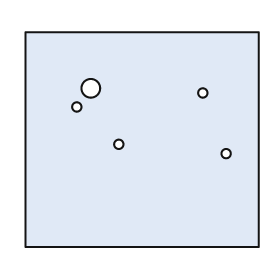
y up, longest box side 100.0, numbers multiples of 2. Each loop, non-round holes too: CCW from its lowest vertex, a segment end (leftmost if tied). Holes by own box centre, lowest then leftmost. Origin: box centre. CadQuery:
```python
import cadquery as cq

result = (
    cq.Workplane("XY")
    .moveTo(-50.0, -46.0)
    .lineTo(50.0, -46.0)
    .lineTo(50.0, 46.0)
    .lineTo(-50.0, 46.0)
    .close()
    .moveTo(36.0, -6.0)
    .circle(2.0)
    .moveTo(-10.0, -2.0)
    .circle(2.0)
    .moveTo(-28.0, 14.0)
    .circle(2.0)
    .moveTo(26.0, 20.0)
    .circle(2.0)
    .moveTo(-22.0, 22.0)
    .circle(4.0)
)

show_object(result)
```